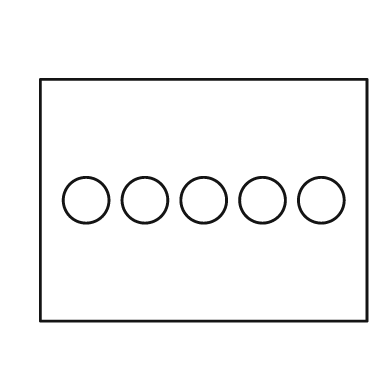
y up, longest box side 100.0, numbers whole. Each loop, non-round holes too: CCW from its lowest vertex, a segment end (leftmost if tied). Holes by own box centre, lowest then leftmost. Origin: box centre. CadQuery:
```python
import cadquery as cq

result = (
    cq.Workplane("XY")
    .moveTo(-50.0, -37.0)
    .lineTo(50.0, -37.0)
    .lineTo(50.0, 37.0)
    .lineTo(-50.0, 37.0)
    .close()
    .moveTo(-36.0, 0.0)
    .circle(7.0)
    .moveTo(-18.0, 0.0)
    .circle(7.0)
    .moveTo(0.0, 0.0)
    .circle(7.0)
    .moveTo(18.0, 0.0)
    .circle(7.0)
    .moveTo(36.0, 0.0)
    .circle(7.0)
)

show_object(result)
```